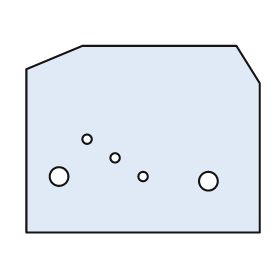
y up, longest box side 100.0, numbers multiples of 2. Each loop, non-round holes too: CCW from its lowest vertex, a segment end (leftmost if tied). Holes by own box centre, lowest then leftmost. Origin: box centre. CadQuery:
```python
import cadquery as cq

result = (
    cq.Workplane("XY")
    .moveTo(-50.0, -40.0)
    .lineTo(50.0, -40.0)
    .lineTo(50.0, 24.0)
    .lineTo(40.0, 40.0)
    .lineTo(-26.0, 40.0)
    .lineTo(-50.0, 30.0)
    .close()
    .moveTo(28.0, -18.0)
    .circle(4.0)
    .moveTo(-36.0, -16.0)
    .circle(4.0)
    .moveTo(0.0, -16.0)
    .circle(2.0)
    .moveTo(-12.0, -8.0)
    .circle(2.0)
    .moveTo(-24.0, 0.0)
    .circle(2.0)
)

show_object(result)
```